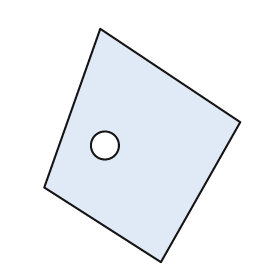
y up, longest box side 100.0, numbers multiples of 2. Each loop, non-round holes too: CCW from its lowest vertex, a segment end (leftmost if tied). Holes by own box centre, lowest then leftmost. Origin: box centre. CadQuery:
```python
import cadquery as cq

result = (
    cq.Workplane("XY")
    .moveTo(8.0, -50.0)
    .lineTo(42.0, 10.0)
    .lineTo(-18.0, 50.0)
    .lineTo(-42.0, -18.0)
    .close()
    .moveTo(-16.0, 0.0)
    .circle(6.0)
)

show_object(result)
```